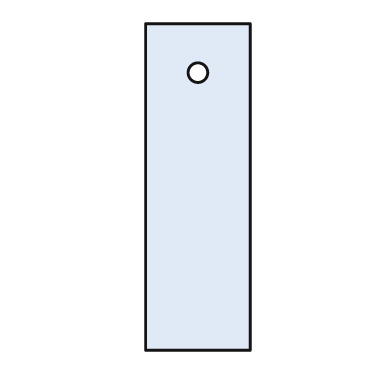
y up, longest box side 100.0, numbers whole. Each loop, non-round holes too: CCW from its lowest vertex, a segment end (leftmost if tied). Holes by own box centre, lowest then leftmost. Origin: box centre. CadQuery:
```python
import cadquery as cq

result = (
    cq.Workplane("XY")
    .moveTo(-16.0, -50.0)
    .lineTo(16.0, -50.0)
    .lineTo(16.0, 50.0)
    .lineTo(-16.0, 50.0)
    .close()
    .moveTo(0.0, 35.0)
    .circle(3.0)
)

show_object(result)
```